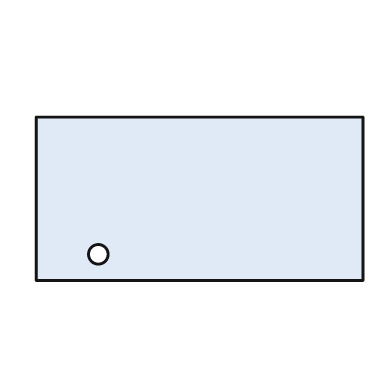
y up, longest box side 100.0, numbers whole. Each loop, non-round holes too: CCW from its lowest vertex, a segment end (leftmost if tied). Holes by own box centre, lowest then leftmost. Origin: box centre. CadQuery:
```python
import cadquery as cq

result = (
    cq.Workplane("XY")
    .moveTo(-50.0, -25.0)
    .lineTo(50.0, -25.0)
    .lineTo(50.0, 25.0)
    .lineTo(-50.0, 25.0)
    .close()
    .moveTo(-31.0, -17.0)
    .circle(3.0)
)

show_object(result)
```